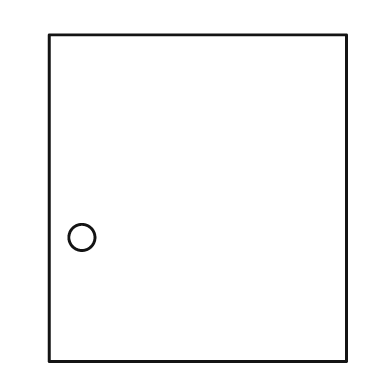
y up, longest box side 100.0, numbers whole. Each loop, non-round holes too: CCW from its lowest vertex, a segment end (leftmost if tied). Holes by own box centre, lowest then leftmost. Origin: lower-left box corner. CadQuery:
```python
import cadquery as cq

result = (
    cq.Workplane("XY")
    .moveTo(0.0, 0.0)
    .lineTo(91.0, 0.0)
    .lineTo(91.0, 100.0)
    .lineTo(0.0, 100.0)
    .close()
    .moveTo(10.0, 38.0)
    .circle(4.0)
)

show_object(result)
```